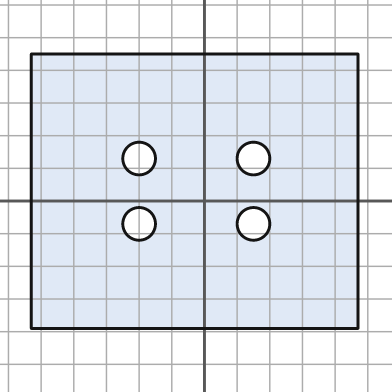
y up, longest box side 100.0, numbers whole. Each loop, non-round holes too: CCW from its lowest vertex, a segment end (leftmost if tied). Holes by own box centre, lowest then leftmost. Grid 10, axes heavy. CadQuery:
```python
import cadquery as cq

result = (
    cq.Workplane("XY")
    .moveTo(-53.0, -39.0)
    .lineTo(47.0, -39.0)
    .lineTo(47.0, 45.0)
    .lineTo(-53.0, 45.0)
    .close()
    .moveTo(-20.0, -7.0)
    .circle(5.0)
    .moveTo(15.0, -7.0)
    .circle(5.0)
    .moveTo(-20.0, 13.0)
    .circle(5.0)
    .moveTo(15.0, 13.0)
    .circle(5.0)
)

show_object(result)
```